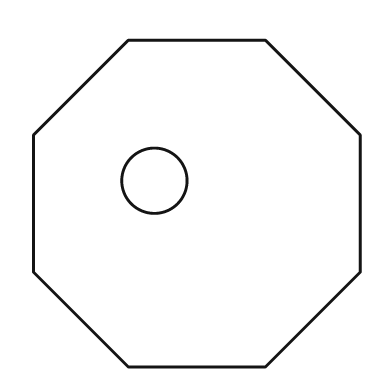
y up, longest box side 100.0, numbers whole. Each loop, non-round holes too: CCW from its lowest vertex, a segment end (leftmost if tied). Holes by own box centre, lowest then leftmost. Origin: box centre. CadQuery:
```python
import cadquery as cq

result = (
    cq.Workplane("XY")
    .moveTo(-21.0, -50.0)
    .lineTo(21.0, -50.0)
    .lineTo(50.0, -21.0)
    .lineTo(50.0, 21.0)
    .lineTo(21.0, 50.0)
    .lineTo(-21.0, 50.0)
    .lineTo(-50.0, 21.0)
    .lineTo(-50.0, -21.0)
    .close()
    .moveTo(-13.0, 7.0)
    .circle(10.0)
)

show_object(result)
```